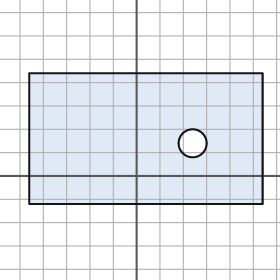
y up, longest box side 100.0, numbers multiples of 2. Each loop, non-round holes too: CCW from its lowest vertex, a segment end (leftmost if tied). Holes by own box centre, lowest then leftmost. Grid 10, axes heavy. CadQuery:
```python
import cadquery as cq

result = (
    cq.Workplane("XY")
    .moveTo(-46.0, -12.0)
    .lineTo(54.0, -12.0)
    .lineTo(54.0, 44.0)
    .lineTo(-46.0, 44.0)
    .close()
    .moveTo(24.0, 14.0)
    .circle(6.0)
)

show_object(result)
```